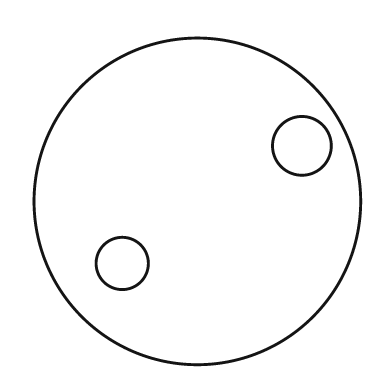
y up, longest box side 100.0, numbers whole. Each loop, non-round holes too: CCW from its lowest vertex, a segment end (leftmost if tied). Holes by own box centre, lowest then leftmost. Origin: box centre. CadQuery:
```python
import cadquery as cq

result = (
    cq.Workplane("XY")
    .moveTo(0.0, 0.0)
    .circle(50.0)
    .moveTo(-23.0, -19.0)
    .circle(8.0)
    .moveTo(32.0, 17.0)
    .circle(9.0)
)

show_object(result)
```